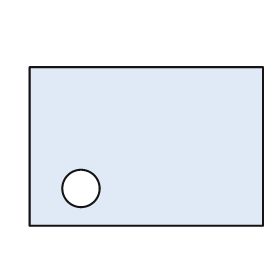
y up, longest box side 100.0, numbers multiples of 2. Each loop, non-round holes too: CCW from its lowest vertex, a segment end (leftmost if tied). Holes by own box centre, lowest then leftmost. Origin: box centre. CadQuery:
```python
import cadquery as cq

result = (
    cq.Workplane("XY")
    .moveTo(-50.0, -34.0)
    .lineTo(50.0, -34.0)
    .lineTo(50.0, 34.0)
    .lineTo(-50.0, 34.0)
    .close()
    .moveTo(-28.0, -18.0)
    .circle(8.0)
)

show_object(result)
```